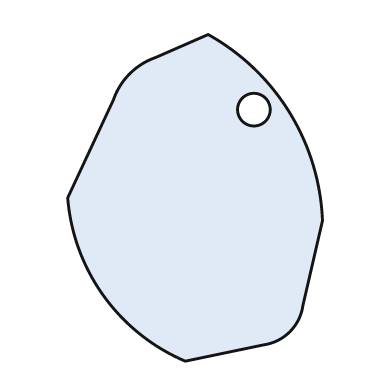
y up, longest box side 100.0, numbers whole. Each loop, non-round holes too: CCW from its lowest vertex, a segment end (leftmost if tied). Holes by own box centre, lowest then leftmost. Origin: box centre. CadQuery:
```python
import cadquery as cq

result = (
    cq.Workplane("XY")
    .moveTo(-3.0, -50.0)
    .lineTo(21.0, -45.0)
    .threePointArc((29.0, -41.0), (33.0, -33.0))
    .lineTo(39.0, -7.0)
    .threePointArc((29.0, 26.0), (4.0, 50.0))
    .lineTo(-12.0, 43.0)
    .threePointArc((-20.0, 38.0), (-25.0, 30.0))
    .lineTo(-39.0, 0.0)
    .threePointArc((-28.0, -30.0), (-3.0, -50.0))
    .close()
    .moveTo(18.0, 27.0)
    .circle(5.0)
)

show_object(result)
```